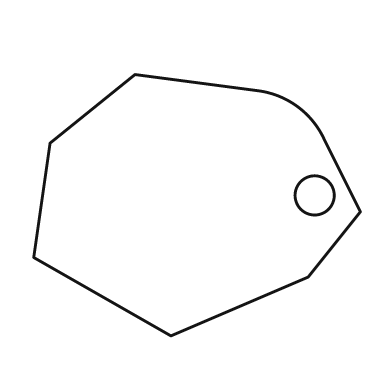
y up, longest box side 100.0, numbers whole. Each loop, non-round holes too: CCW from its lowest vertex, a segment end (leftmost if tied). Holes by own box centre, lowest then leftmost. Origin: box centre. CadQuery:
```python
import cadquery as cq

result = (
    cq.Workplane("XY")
    .moveTo(-8.0, -40.0)
    .lineTo(34.0, -22.0)
    .lineTo(50.0, -2.0)
    .lineTo(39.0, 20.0)
    .threePointArc((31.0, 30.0), (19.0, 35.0))
    .lineTo(-19.0, 40.0)
    .lineTo(-45.0, 19.0)
    .lineTo(-50.0, -16.0)
    .close()
    .moveTo(36.0, 3.0)
    .circle(6.0)
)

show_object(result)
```